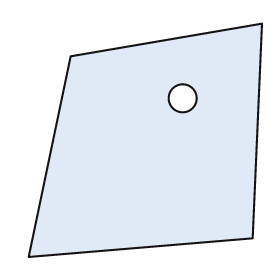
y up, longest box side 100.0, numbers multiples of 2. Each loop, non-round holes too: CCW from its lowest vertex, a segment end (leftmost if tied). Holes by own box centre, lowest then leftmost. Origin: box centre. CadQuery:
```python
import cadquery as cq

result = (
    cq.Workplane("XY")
    .moveTo(-50.0, -50.0)
    .lineTo(46.0, -42.0)
    .lineTo(50.0, 50.0)
    .lineTo(-32.0, 36.0)
    .close()
    .moveTo(16.0, 18.0)
    .circle(6.0)
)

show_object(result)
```